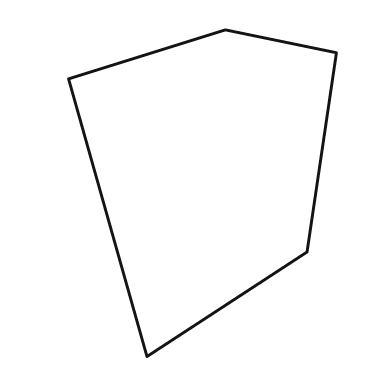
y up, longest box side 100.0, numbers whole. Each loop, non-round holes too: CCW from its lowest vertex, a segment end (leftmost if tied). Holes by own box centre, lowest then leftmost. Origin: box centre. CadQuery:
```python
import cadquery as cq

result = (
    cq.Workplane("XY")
    .moveTo(-17.0, -50.0)
    .lineTo(32.0, -18.0)
    .lineTo(41.0, 43.0)
    .lineTo(7.0, 50.0)
    .lineTo(-41.0, 35.0)
    .close()
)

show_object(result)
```